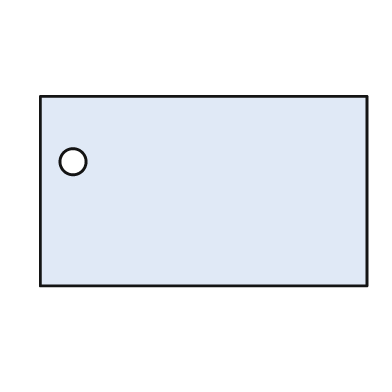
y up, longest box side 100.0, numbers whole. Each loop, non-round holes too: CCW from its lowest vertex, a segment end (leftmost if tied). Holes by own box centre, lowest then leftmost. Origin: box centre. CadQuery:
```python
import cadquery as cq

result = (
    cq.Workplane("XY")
    .moveTo(-50.0, -29.0)
    .lineTo(50.0, -29.0)
    .lineTo(50.0, 29.0)
    .lineTo(-50.0, 29.0)
    .close()
    .moveTo(-40.0, 9.0)
    .circle(4.0)
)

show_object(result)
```